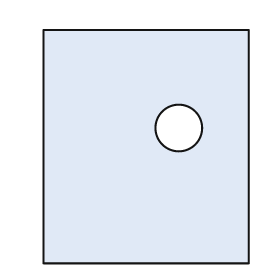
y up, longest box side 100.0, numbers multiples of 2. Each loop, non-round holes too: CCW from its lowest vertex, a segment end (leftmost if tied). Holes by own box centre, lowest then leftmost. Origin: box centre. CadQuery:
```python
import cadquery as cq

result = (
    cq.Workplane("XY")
    .moveTo(-44.0, -50.0)
    .lineTo(44.0, -50.0)
    .lineTo(44.0, 50.0)
    .lineTo(-44.0, 50.0)
    .close()
    .moveTo(14.0, 8.0)
    .circle(10.0)
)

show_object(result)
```